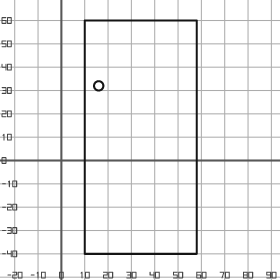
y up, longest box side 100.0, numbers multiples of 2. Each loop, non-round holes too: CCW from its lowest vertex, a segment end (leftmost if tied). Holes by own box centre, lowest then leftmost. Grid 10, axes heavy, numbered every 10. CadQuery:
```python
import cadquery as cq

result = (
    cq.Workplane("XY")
    .moveTo(10.0, -40.0)
    .lineTo(58.0, -40.0)
    .lineTo(58.0, 60.0)
    .lineTo(10.0, 60.0)
    .close()
    .moveTo(16.0, 32.0)
    .circle(2.0)
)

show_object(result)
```